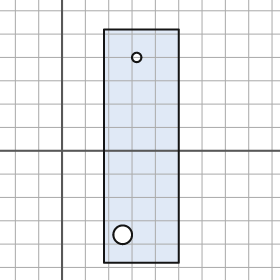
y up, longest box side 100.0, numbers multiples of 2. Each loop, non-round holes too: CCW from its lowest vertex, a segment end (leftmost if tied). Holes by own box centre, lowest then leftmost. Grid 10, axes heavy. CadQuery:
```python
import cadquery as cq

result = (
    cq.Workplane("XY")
    .moveTo(18.0, -48.0)
    .lineTo(50.0, -48.0)
    .lineTo(50.0, 52.0)
    .lineTo(18.0, 52.0)
    .close()
    .moveTo(26.0, -36.0)
    .circle(4.0)
    .moveTo(32.0, 40.0)
    .circle(2.0)
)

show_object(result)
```